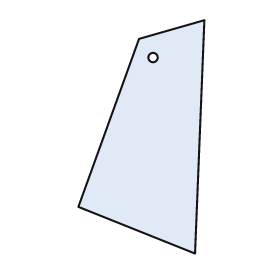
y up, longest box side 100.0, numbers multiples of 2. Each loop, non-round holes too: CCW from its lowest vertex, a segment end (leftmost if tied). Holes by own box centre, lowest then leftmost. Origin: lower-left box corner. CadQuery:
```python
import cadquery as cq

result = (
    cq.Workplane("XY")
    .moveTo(50.0, 0.0)
    .lineTo(54.0, 100.0)
    .lineTo(26.0, 92.0)
    .lineTo(0.0, 20.0)
    .close()
    .moveTo(32.0, 84.0)
    .circle(2.0)
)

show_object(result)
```